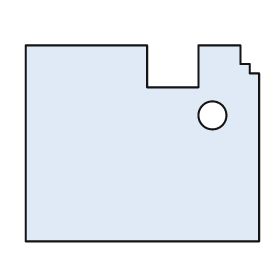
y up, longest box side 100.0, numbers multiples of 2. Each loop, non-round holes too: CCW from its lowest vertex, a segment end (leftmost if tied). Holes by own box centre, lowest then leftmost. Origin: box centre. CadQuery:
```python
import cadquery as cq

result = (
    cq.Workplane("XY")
    .moveTo(-50.0, -42.0)
    .lineTo(50.0, -42.0)
    .lineTo(50.0, 30.0)
    .lineTo(46.0, 30.0)
    .lineTo(46.0, 34.0)
    .lineTo(42.0, 34.0)
    .lineTo(42.0, 42.0)
    .lineTo(24.0, 42.0)
    .lineTo(24.0, 24.0)
    .lineTo(2.0, 24.0)
    .lineTo(2.0, 42.0)
    .lineTo(-50.0, 42.0)
    .close()
    .moveTo(30.0, 12.0)
    .circle(6.0)
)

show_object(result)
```